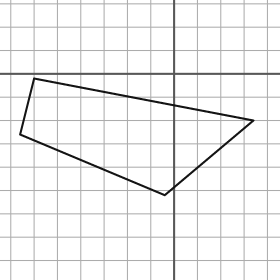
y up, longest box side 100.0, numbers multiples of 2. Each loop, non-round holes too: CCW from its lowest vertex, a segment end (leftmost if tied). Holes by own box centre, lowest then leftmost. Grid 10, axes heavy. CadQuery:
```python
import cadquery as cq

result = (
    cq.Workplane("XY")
    .moveTo(-4.0, -52.0)
    .lineTo(34.0, -20.0)
    .lineTo(-60.0, -2.0)
    .lineTo(-66.0, -26.0)
    .close()
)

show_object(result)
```